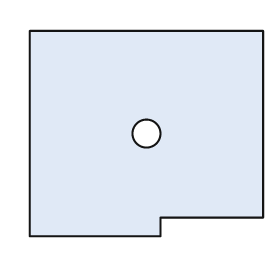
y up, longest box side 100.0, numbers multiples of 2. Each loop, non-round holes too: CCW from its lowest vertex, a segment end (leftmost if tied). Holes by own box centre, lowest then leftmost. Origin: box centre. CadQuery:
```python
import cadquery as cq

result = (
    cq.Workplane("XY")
    .moveTo(-50.0, -44.0)
    .lineTo(6.0, -44.0)
    .lineTo(6.0, -36.0)
    .lineTo(50.0, -36.0)
    .lineTo(50.0, 44.0)
    .lineTo(-50.0, 44.0)
    .close()
    .moveTo(0.0, 0.0)
    .circle(6.0)
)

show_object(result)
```